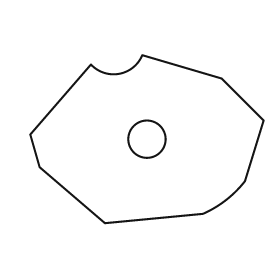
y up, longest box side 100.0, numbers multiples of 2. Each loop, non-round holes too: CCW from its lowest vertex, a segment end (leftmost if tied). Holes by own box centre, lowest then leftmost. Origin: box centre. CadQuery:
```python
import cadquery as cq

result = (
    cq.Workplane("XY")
    .moveTo(-18.0, -36.0)
    .lineTo(24.0, -32.0)
    .threePointArc((34.0, -26.0), (42.0, -18.0))
    .lineTo(50.0, 8.0)
    .lineTo(32.0, 26.0)
    .lineTo(-2.0, 36.0)
    .threePointArc((-12.0, 28.0), (-24.0, 32.0))
    .lineTo(-50.0, 2.0)
    .lineTo(-46.0, -12.0)
    .close()
    .moveTo(0.0, 0.0)
    .circle(8.0)
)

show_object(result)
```